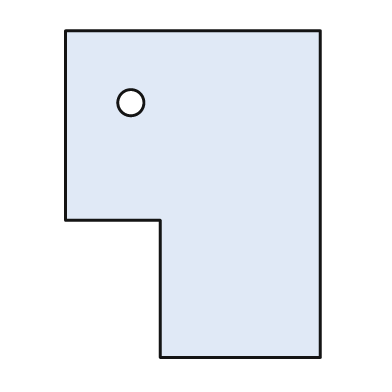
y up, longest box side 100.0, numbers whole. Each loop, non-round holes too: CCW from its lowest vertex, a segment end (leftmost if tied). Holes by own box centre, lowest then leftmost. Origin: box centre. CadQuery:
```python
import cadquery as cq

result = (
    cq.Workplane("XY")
    .moveTo(-10.0, -50.0)
    .lineTo(39.0, -50.0)
    .lineTo(39.0, 50.0)
    .lineTo(-39.0, 50.0)
    .lineTo(-39.0, -8.0)
    .lineTo(-10.0, -8.0)
    .close()
    .moveTo(-19.0, 28.0)
    .circle(4.0)
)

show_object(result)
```